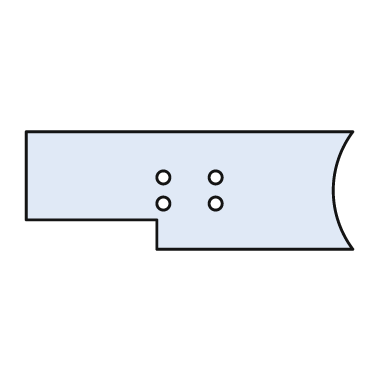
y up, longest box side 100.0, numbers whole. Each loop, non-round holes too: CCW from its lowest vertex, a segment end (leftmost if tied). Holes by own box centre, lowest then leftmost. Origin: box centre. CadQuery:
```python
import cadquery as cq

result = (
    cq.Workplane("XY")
    .moveTo(-10.0, -18.0)
    .lineTo(50.0, -18.0)
    .threePointArc((44.0, 0.0), (50.0, 18.0))
    .lineTo(-50.0, 18.0)
    .lineTo(-50.0, -9.0)
    .lineTo(-10.0, -9.0)
    .close()
    .moveTo(-8.0, -4.0)
    .circle(2.0)
    .moveTo(8.0, -4.0)
    .circle(2.0)
    .moveTo(-8.0, 4.0)
    .circle(2.0)
    .moveTo(8.0, 4.0)
    .circle(2.0)
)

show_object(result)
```